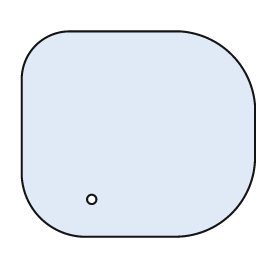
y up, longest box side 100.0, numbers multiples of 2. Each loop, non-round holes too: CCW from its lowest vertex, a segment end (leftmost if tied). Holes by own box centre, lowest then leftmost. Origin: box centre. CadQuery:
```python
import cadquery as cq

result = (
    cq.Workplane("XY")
    .moveTo(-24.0, -44.0)
    .lineTo(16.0, -44.0)
    .threePointArc((40.0, -34.0), (50.0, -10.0))
    .lineTo(50.0, 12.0)
    .threePointArc((40.0, 34.0), (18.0, 44.0))
    .lineTo(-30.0, 44.0)
    .threePointArc((-44.0, 38.0), (-50.0, 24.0))
    .lineTo(-50.0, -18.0)
    .threePointArc((-42.0, -36.0), (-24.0, -44.0))
    .close()
    .moveTo(-20.0, -28.0)
    .circle(2.0)
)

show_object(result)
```